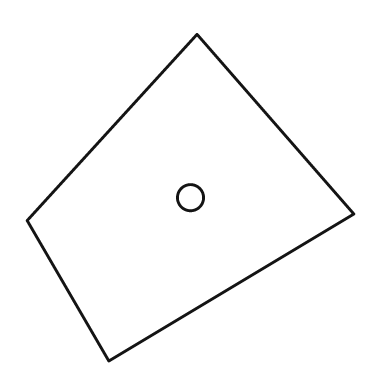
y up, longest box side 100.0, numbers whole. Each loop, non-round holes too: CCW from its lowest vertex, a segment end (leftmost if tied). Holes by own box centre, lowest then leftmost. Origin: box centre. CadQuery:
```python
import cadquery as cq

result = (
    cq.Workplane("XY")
    .moveTo(-25.0, -50.0)
    .lineTo(50.0, -5.0)
    .lineTo(2.0, 50.0)
    .lineTo(-50.0, -7.0)
    .close()
    .moveTo(0.0, 0.0)
    .circle(4.0)
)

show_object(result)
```